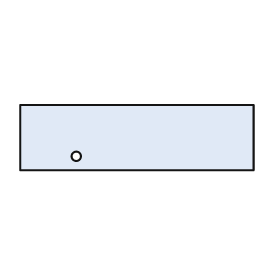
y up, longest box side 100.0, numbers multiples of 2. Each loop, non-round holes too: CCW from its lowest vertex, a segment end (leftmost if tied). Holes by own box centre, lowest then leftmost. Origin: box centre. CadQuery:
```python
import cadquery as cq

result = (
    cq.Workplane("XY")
    .moveTo(-50.0, -14.0)
    .lineTo(50.0, -14.0)
    .lineTo(50.0, 14.0)
    .lineTo(-50.0, 14.0)
    .close()
    .moveTo(-26.0, -8.0)
    .circle(2.0)
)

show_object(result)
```